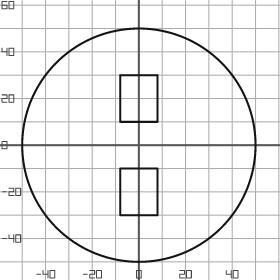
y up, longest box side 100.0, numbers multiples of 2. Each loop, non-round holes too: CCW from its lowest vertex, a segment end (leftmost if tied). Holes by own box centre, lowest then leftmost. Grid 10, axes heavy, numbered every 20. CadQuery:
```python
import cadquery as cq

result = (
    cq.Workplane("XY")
    .moveTo(0.0, 0.0)
    .circle(50.0)
    .moveTo(-8.0, -30.0)
    .lineTo(8.0, -30.0)
    .lineTo(8.0, -10.0)
    .lineTo(-8.0, -10.0)
    .close()
    .moveTo(-8.0, 10.0)
    .lineTo(8.0, 10.0)
    .lineTo(8.0, 30.0)
    .lineTo(-8.0, 30.0)
    .close()
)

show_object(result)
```